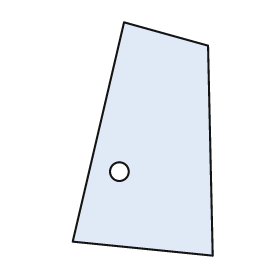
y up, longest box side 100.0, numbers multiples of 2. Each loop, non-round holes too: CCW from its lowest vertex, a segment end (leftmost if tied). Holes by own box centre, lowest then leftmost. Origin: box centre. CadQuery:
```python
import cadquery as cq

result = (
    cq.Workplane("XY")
    .moveTo(30.0, -50.0)
    .lineTo(28.0, 40.0)
    .lineTo(-8.0, 50.0)
    .lineTo(-30.0, -44.0)
    .close()
    .moveTo(-10.0, -14.0)
    .circle(4.0)
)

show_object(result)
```